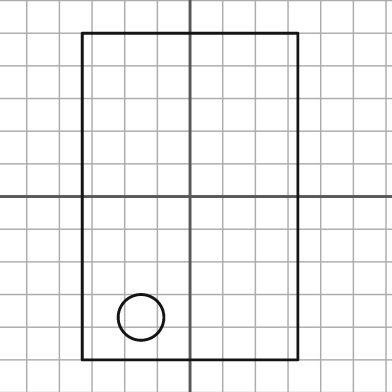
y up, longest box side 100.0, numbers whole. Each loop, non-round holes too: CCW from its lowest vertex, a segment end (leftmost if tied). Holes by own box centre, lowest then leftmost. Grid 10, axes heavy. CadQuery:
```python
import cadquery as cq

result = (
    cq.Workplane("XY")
    .moveTo(-33.0, -50.0)
    .lineTo(33.0, -50.0)
    .lineTo(33.0, 50.0)
    .lineTo(-33.0, 50.0)
    .close()
    .moveTo(-15.0, -37.0)
    .circle(7.0)
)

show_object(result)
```